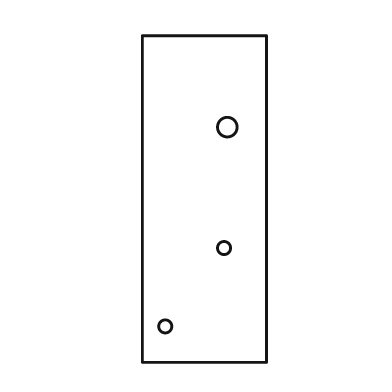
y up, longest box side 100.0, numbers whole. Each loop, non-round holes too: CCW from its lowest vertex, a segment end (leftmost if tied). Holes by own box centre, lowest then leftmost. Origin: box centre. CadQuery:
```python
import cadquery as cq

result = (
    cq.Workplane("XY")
    .moveTo(-19.0, -50.0)
    .lineTo(19.0, -50.0)
    .lineTo(19.0, 50.0)
    .lineTo(-19.0, 50.0)
    .close()
    .moveTo(-12.0, -39.0)
    .circle(2.0)
    .moveTo(6.0, -15.0)
    .circle(2.0)
    .moveTo(7.0, 22.0)
    .circle(3.0)
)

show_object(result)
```